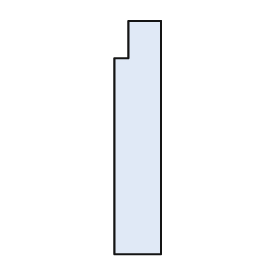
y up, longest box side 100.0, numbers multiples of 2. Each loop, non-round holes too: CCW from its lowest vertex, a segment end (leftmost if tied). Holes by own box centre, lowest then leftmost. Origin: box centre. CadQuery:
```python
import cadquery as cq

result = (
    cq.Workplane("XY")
    .moveTo(-10.0, -50.0)
    .lineTo(10.0, -50.0)
    .lineTo(10.0, 50.0)
    .lineTo(-4.0, 50.0)
    .lineTo(-4.0, 34.0)
    .lineTo(-10.0, 34.0)
    .close()
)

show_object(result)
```